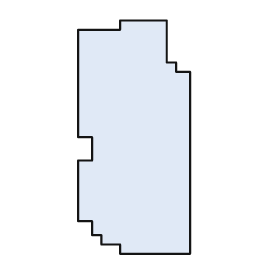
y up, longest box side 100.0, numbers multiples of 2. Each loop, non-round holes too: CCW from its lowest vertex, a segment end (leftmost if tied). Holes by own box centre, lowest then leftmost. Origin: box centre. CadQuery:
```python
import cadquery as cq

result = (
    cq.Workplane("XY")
    .moveTo(-6.0, -50.0)
    .lineTo(24.0, -50.0)
    .lineTo(24.0, 28.0)
    .lineTo(18.0, 28.0)
    .lineTo(18.0, 32.0)
    .lineTo(14.0, 32.0)
    .lineTo(14.0, 50.0)
    .lineTo(-6.0, 50.0)
    .lineTo(-6.0, 46.0)
    .lineTo(-24.0, 46.0)
    .lineTo(-24.0, 0.0)
    .lineTo(-18.0, 0.0)
    .lineTo(-18.0, -10.0)
    .lineTo(-24.0, -10.0)
    .lineTo(-24.0, -36.0)
    .lineTo(-18.0, -36.0)
    .lineTo(-18.0, -42.0)
    .lineTo(-14.0, -42.0)
    .lineTo(-14.0, -46.0)
    .lineTo(-6.0, -46.0)
    .close()
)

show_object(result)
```